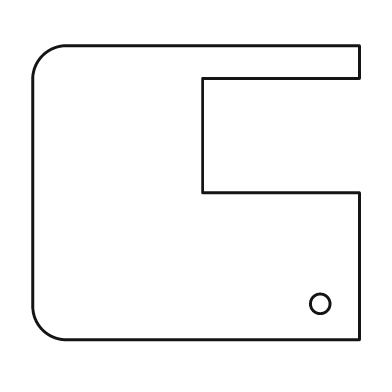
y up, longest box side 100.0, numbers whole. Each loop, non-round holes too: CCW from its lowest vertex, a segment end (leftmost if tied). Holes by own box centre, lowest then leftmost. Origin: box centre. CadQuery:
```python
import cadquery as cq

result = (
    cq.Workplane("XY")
    .moveTo(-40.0, -45.0)
    .lineTo(50.0, -45.0)
    .lineTo(50.0, 0.0)
    .lineTo(2.0, 0.0)
    .lineTo(2.0, 35.0)
    .lineTo(50.0, 35.0)
    .lineTo(50.0, 45.0)
    .lineTo(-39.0, 45.0)
    .threePointArc((-47.0, 42.0), (-50.0, 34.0))
    .lineTo(-50.0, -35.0)
    .threePointArc((-47.0, -42.0), (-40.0, -45.0))
    .close()
    .moveTo(38.0, -34.0)
    .circle(3.0)
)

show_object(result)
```